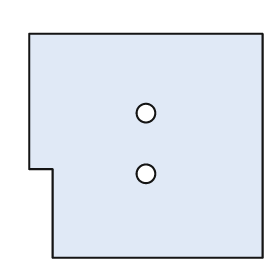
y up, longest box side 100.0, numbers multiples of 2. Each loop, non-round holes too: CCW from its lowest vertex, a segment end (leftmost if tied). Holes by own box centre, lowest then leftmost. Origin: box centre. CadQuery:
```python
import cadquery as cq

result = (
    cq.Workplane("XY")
    .moveTo(-40.0, -48.0)
    .lineTo(50.0, -48.0)
    .lineTo(50.0, 48.0)
    .lineTo(-50.0, 48.0)
    .lineTo(-50.0, -10.0)
    .lineTo(-40.0, -10.0)
    .close()
    .moveTo(0.0, -12.0)
    .circle(4.0)
    .moveTo(0.0, 14.0)
    .circle(4.0)
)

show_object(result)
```